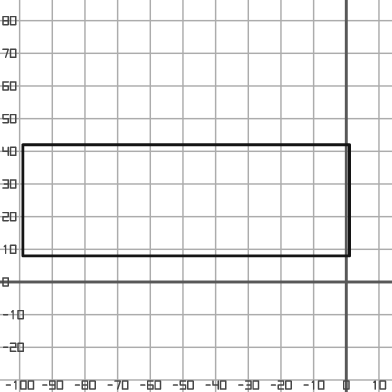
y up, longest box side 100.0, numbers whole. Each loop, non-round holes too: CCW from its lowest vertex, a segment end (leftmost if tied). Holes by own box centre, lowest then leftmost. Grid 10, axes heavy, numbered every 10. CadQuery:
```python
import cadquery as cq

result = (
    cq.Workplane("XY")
    .moveTo(-99.0, 8.0)
    .lineTo(1.0, 8.0)
    .lineTo(1.0, 42.0)
    .lineTo(-99.0, 42.0)
    .close()
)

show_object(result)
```